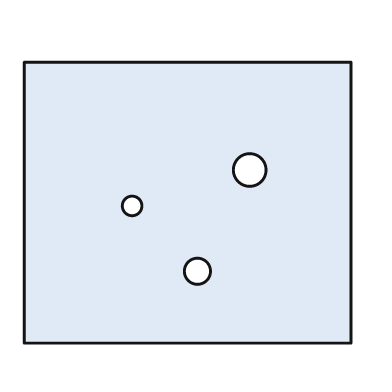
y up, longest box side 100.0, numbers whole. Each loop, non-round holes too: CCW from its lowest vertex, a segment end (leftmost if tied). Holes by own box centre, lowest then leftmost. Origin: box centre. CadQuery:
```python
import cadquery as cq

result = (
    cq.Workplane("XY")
    .moveTo(-50.0, -43.0)
    .lineTo(50.0, -43.0)
    .lineTo(50.0, 43.0)
    .lineTo(-50.0, 43.0)
    .close()
    .moveTo(3.0, -21.0)
    .circle(4.0)
    .moveTo(-17.0, -1.0)
    .circle(3.0)
    .moveTo(19.0, 10.0)
    .circle(5.0)
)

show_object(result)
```